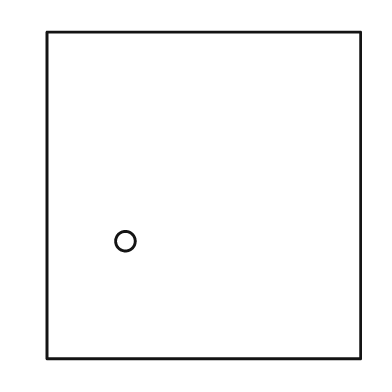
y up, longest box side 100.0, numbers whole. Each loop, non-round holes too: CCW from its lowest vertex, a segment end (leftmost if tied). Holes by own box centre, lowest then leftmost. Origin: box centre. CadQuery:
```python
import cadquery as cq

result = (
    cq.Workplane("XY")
    .moveTo(-48.0, -50.0)
    .lineTo(48.0, -50.0)
    .lineTo(48.0, 50.0)
    .lineTo(-48.0, 50.0)
    .close()
    .moveTo(-24.0, -14.0)
    .circle(3.0)
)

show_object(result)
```